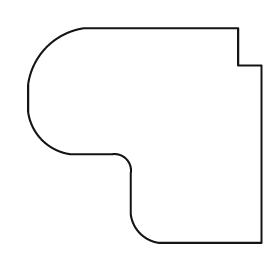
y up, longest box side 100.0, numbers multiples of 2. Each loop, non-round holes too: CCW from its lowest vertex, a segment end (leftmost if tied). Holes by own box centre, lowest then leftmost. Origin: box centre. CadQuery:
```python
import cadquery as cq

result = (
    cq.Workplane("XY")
    .moveTo(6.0, -46.0)
    .lineTo(50.0, -46.0)
    .lineTo(50.0, 30.0)
    .lineTo(40.0, 30.0)
    .lineTo(40.0, 46.0)
    .lineTo(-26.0, 46.0)
    .threePointArc((-42.0, 38.0), (-50.0, 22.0))
    .lineTo(-50.0, 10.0)
    .threePointArc((-44.0, -2.0), (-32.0, -8.0))
    .lineTo(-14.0, -8.0)
    .threePointArc((-8.0, -10.0), (-6.0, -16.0))
    .lineTo(-6.0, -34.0)
    .threePointArc((-2.0, -42.0), (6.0, -46.0))
    .close()
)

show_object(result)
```